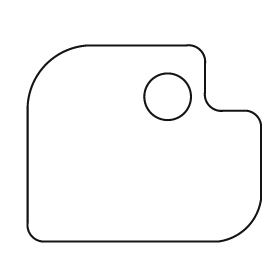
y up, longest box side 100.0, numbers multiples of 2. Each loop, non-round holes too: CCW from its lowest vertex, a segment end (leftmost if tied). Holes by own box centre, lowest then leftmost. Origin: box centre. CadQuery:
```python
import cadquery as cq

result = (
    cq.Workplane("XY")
    .moveTo(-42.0, -42.0)
    .lineTo(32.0, -42.0)
    .threePointArc((44.0, -36.0), (50.0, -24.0))
    .lineTo(50.0, 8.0)
    .threePointArc((48.0, 12.0), (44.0, 14.0))
    .lineTo(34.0, 14.0)
    .threePointArc((28.0, 16.0), (26.0, 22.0))
    .lineTo(26.0, 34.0)
    .threePointArc((24.0, 40.0), (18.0, 42.0))
    .lineTo(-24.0, 42.0)
    .threePointArc((-42.0, 34.0), (-50.0, 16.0))
    .lineTo(-50.0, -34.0)
    .threePointArc((-48.0, -40.0), (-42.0, -42.0))
    .close()
    .moveTo(10.0, 20.0)
    .circle(10.0)
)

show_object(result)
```